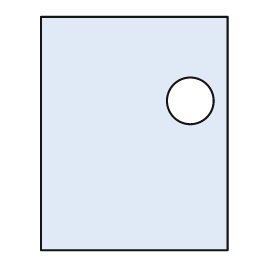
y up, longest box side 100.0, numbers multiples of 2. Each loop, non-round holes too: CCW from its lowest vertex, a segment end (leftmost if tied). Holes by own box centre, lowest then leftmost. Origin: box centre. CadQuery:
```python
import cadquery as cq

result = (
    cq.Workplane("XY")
    .moveTo(-40.0, -50.0)
    .lineTo(40.0, -50.0)
    .lineTo(40.0, 50.0)
    .lineTo(-40.0, 50.0)
    .close()
    .moveTo(24.0, 14.0)
    .circle(10.0)
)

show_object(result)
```